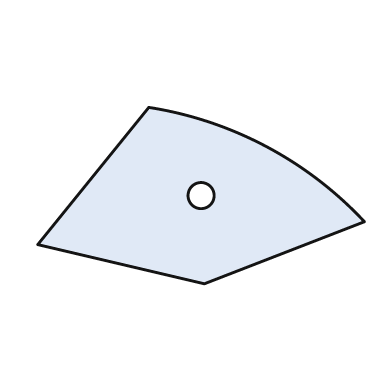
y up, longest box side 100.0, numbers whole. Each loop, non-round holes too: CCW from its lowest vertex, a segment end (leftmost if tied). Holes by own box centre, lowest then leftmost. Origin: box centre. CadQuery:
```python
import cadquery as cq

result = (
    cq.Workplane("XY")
    .moveTo(1.0, -27.0)
    .lineTo(50.0, -8.0)
    .threePointArc((20.0, 15.0), (-16.0, 27.0))
    .lineTo(-50.0, -15.0)
    .close()
    .moveTo(0.0, 0.0)
    .circle(4.0)
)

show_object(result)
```